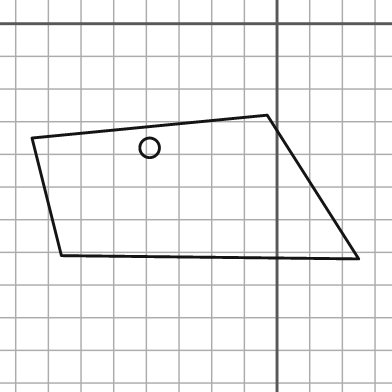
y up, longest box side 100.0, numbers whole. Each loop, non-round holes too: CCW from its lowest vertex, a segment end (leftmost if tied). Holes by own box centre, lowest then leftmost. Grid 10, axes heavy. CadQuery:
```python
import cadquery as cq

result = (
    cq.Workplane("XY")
    .moveTo(25.0, -72.0)
    .lineTo(-3.0, -28.0)
    .lineTo(-75.0, -35.0)
    .lineTo(-66.0, -71.0)
    .close()
    .moveTo(-39.0, -38.0)
    .circle(3.0)
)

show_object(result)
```